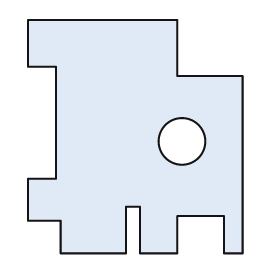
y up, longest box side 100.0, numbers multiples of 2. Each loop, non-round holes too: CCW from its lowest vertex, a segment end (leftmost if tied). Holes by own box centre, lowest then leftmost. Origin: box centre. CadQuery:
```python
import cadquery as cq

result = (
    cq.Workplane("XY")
    .moveTo(-32.0, -50.0)
    .lineTo(-4.0, -50.0)
    .lineTo(-4.0, -30.0)
    .lineTo(2.0, -30.0)
    .lineTo(2.0, -50.0)
    .lineTo(18.0, -50.0)
    .lineTo(18.0, -34.0)
    .lineTo(38.0, -34.0)
    .lineTo(38.0, -50.0)
    .lineTo(46.0, -50.0)
    .lineTo(46.0, 26.0)
    .lineTo(18.0, 26.0)
    .lineTo(18.0, 50.0)
    .lineTo(-46.0, 50.0)
    .lineTo(-46.0, 30.0)
    .lineTo(-34.0, 30.0)
    .lineTo(-34.0, -18.0)
    .lineTo(-46.0, -18.0)
    .lineTo(-46.0, -36.0)
    .lineTo(-32.0, -36.0)
    .close()
    .moveTo(20.0, -2.0)
    .circle(10.0)
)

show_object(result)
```